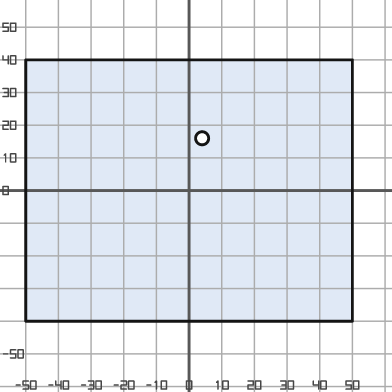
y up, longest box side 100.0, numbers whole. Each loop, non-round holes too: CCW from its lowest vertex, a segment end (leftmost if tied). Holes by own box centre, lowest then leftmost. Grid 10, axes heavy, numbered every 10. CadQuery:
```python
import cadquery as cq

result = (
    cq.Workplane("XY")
    .moveTo(-50.0, -40.0)
    .lineTo(50.0, -40.0)
    .lineTo(50.0, 40.0)
    .lineTo(-50.0, 40.0)
    .close()
    .moveTo(4.0, 16.0)
    .circle(2.0)
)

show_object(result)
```